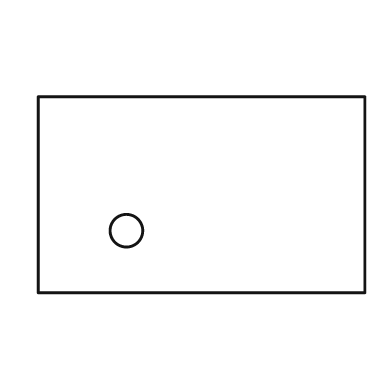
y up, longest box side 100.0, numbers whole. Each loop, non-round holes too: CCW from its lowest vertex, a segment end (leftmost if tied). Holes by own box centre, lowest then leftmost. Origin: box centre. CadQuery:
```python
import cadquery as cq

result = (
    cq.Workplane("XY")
    .moveTo(-50.0, -30.0)
    .lineTo(50.0, -30.0)
    .lineTo(50.0, 30.0)
    .lineTo(-50.0, 30.0)
    .close()
    .moveTo(-23.0, -11.0)
    .circle(5.0)
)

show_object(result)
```